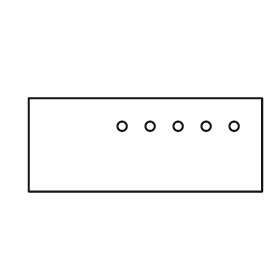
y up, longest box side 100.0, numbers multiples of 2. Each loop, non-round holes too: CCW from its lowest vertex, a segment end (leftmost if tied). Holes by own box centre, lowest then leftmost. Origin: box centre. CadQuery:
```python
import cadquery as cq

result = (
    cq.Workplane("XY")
    .moveTo(-50.0, -20.0)
    .lineTo(50.0, -20.0)
    .lineTo(50.0, 20.0)
    .lineTo(-50.0, 20.0)
    .close()
    .moveTo(-10.0, 8.0)
    .circle(2.0)
    .moveTo(2.0, 8.0)
    .circle(2.0)
    .moveTo(14.0, 8.0)
    .circle(2.0)
    .moveTo(26.0, 8.0)
    .circle(2.0)
    .moveTo(38.0, 8.0)
    .circle(2.0)
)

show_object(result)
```